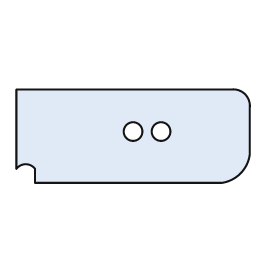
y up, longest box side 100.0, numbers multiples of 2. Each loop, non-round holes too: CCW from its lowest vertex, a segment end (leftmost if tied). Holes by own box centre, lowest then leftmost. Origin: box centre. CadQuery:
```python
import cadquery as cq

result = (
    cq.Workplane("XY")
    .moveTo(-42.0, -20.0)
    .lineTo(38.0, -20.0)
    .threePointArc((46.0, -16.0), (50.0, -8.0))
    .lineTo(50.0, 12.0)
    .threePointArc((48.0, 18.0), (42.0, 20.0))
    .lineTo(-50.0, 20.0)
    .lineTo(-50.0, -14.0)
    .threePointArc((-46.0, -12.0), (-42.0, -14.0))
    .close()
    .moveTo(0.0, 2.0)
    .circle(4.0)
    .moveTo(12.0, 2.0)
    .circle(4.0)
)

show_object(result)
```